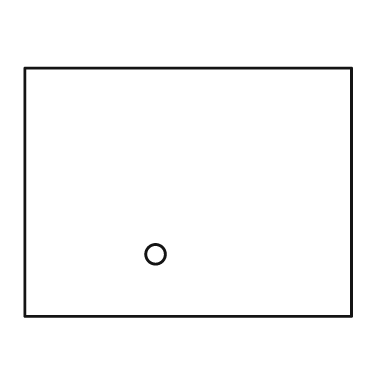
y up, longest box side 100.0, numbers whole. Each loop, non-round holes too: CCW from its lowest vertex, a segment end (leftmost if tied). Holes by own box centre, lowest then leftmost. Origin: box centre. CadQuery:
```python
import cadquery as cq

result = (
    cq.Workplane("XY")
    .moveTo(-50.0, -38.0)
    .lineTo(50.0, -38.0)
    .lineTo(50.0, 38.0)
    .lineTo(-50.0, 38.0)
    .close()
    .moveTo(-10.0, -19.0)
    .circle(3.0)
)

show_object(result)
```